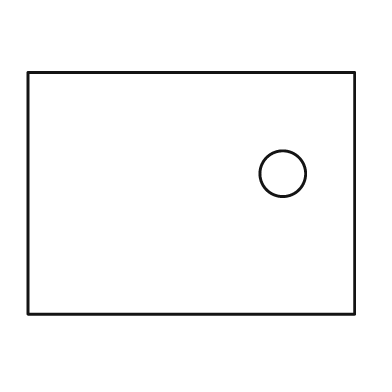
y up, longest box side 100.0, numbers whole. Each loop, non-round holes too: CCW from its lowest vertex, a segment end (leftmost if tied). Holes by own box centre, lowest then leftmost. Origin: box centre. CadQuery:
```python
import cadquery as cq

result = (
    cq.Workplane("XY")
    .moveTo(-50.0, -37.0)
    .lineTo(50.0, -37.0)
    .lineTo(50.0, 37.0)
    .lineTo(-50.0, 37.0)
    .close()
    .moveTo(28.0, 6.0)
    .circle(7.0)
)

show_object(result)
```